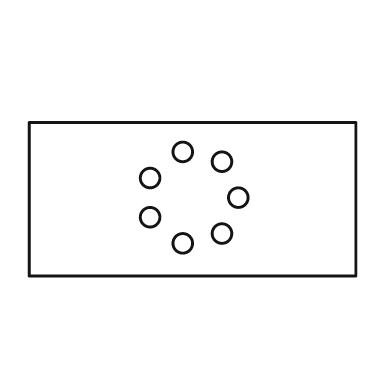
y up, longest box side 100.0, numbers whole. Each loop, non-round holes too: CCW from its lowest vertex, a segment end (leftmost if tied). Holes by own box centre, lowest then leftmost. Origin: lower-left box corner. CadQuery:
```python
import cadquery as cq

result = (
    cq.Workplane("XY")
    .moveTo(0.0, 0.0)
    .lineTo(100.0, 0.0)
    .lineTo(100.0, 47.0)
    .lineTo(0.0, 47.0)
    .close()
    .moveTo(47.0, 10.0)
    .circle(3.0)
    .moveTo(59.0, 13.0)
    .circle(3.0)
    .moveTo(37.0, 18.0)
    .circle(3.0)
    .moveTo(64.0, 24.0)
    .circle(3.0)
    .moveTo(37.0, 30.0)
    .circle(3.0)
    .moveTo(59.0, 35.0)
    .circle(3.0)
    .moveTo(47.0, 38.0)
    .circle(3.0)
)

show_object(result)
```